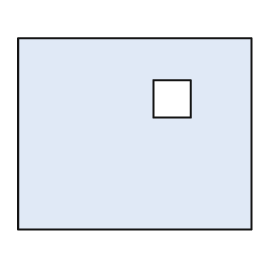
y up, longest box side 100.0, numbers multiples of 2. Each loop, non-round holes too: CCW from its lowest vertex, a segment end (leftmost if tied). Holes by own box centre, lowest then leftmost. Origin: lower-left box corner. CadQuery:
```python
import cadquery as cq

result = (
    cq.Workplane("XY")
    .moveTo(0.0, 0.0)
    .lineTo(100.0, 0.0)
    .lineTo(100.0, 82.0)
    .lineTo(0.0, 82.0)
    .close()
    .moveTo(58.0, 48.0)
    .lineTo(74.0, 48.0)
    .lineTo(74.0, 64.0)
    .lineTo(58.0, 64.0)
    .close()
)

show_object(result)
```